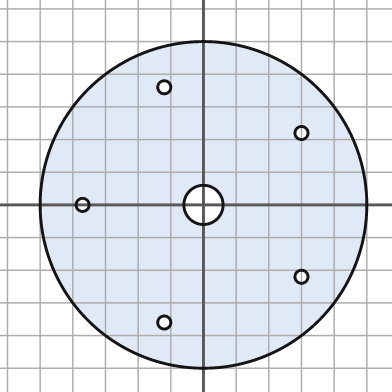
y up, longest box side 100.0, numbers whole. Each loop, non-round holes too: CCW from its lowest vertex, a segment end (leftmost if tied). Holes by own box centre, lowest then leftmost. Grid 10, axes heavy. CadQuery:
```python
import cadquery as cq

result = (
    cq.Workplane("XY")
    .moveTo(0.0, 0.0)
    .circle(50.0)
    .moveTo(-12.0, -36.0)
    .circle(2.0)
    .moveTo(30.0, -22.0)
    .circle(2.0)
    .moveTo(-37.0, 0.0)
    .circle(2.0)
    .moveTo(0.0, 0.0)
    .circle(6.0)
    .moveTo(30.0, 22.0)
    .circle(2.0)
    .moveTo(-12.0, 36.0)
    .circle(2.0)
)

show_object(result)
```